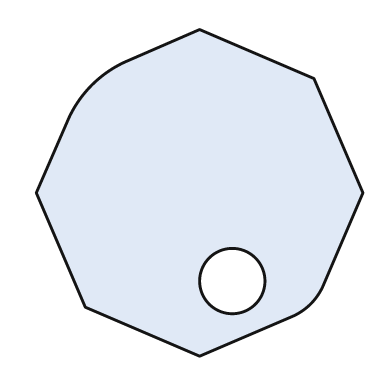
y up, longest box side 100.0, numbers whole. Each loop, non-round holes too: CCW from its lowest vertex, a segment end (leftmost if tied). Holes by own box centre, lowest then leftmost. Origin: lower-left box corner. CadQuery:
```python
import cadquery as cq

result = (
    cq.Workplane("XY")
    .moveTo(50.0, 0.0)
    .lineTo(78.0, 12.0)
    .threePointArc((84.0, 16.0), (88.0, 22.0))
    .lineTo(100.0, 50.0)
    .lineTo(85.0, 85.0)
    .lineTo(50.0, 100.0)
    .lineTo(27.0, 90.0)
    .threePointArc((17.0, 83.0), (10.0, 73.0))
    .lineTo(0.0, 50.0)
    .lineTo(15.0, 15.0)
    .close()
    .moveTo(60.0, 23.0)
    .circle(10.0)
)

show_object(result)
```